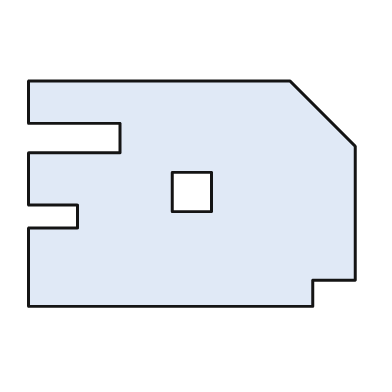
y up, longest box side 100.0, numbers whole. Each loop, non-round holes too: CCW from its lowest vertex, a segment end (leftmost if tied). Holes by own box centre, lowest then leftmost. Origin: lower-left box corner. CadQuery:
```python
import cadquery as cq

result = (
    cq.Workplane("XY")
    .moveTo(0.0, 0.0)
    .lineTo(87.0, 0.0)
    .lineTo(87.0, 8.0)
    .lineTo(100.0, 8.0)
    .lineTo(100.0, 49.0)
    .lineTo(80.0, 69.0)
    .lineTo(0.0, 69.0)
    .lineTo(0.0, 56.0)
    .lineTo(28.0, 56.0)
    .lineTo(28.0, 47.0)
    .lineTo(0.0, 47.0)
    .lineTo(0.0, 31.0)
    .lineTo(15.0, 31.0)
    .lineTo(15.0, 24.0)
    .lineTo(0.0, 24.0)
    .close()
    .moveTo(44.0, 29.0)
    .lineTo(56.0, 29.0)
    .lineTo(56.0, 41.0)
    .lineTo(44.0, 41.0)
    .close()
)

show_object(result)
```